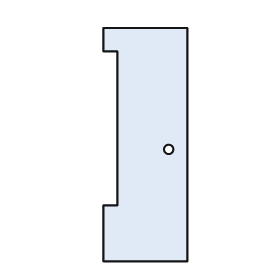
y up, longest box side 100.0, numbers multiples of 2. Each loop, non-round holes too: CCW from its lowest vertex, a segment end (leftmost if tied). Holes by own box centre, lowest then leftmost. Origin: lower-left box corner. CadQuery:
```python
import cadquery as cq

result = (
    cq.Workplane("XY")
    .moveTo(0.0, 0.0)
    .lineTo(36.0, 0.0)
    .lineTo(36.0, 100.0)
    .lineTo(0.0, 100.0)
    .lineTo(0.0, 90.0)
    .lineTo(6.0, 90.0)
    .lineTo(6.0, 24.0)
    .lineTo(0.0, 24.0)
    .close()
    .moveTo(28.0, 48.0)
    .circle(2.0)
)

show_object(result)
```